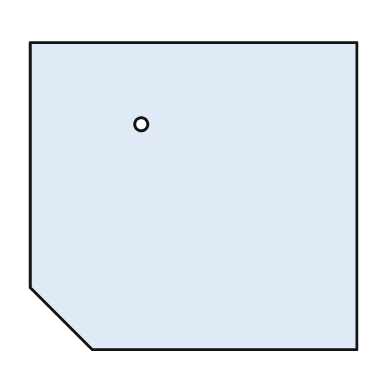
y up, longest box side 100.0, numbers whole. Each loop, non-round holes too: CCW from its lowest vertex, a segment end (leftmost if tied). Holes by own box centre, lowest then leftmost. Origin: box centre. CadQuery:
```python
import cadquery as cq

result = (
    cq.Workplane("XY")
    .moveTo(-31.0, -47.0)
    .lineTo(50.0, -47.0)
    .lineTo(50.0, 47.0)
    .lineTo(-50.0, 47.0)
    .lineTo(-50.0, -28.0)
    .close()
    .moveTo(-16.0, 22.0)
    .circle(2.0)
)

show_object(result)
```